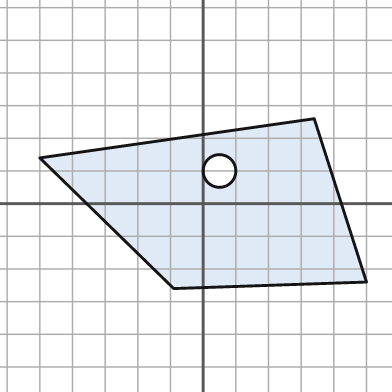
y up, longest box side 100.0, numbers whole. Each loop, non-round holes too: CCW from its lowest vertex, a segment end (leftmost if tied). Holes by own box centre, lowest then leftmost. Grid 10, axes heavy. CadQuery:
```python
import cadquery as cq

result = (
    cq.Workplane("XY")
    .moveTo(-9.0, -26.0)
    .lineTo(50.0, -24.0)
    .lineTo(34.0, 26.0)
    .lineTo(-50.0, 14.0)
    .close()
    .moveTo(5.0, 10.0)
    .circle(5.0)
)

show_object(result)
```